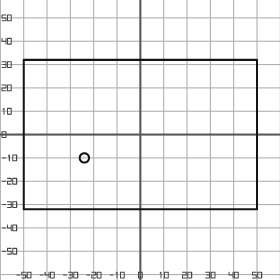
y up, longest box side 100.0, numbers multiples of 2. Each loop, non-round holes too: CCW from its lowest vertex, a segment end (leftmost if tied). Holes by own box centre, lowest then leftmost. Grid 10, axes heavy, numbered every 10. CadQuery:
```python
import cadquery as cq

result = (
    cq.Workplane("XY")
    .moveTo(-50.0, -32.0)
    .lineTo(50.0, -32.0)
    .lineTo(50.0, 32.0)
    .lineTo(-50.0, 32.0)
    .close()
    .moveTo(-24.0, -10.0)
    .circle(2.0)
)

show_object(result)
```